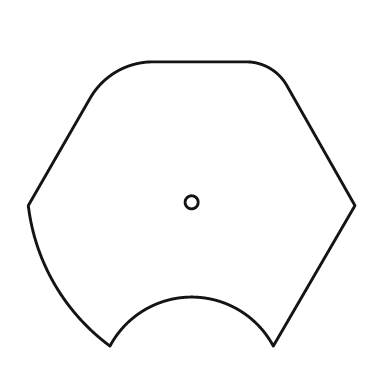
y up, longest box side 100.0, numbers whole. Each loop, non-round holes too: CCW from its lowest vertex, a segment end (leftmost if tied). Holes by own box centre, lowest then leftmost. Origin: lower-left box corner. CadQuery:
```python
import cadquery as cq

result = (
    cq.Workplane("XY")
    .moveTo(25.0, 0.0)
    .threePointArc((50.0, 15.0), (75.0, 0.0))
    .lineTo(100.0, 43.0)
    .lineTo(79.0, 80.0)
    .threePointArc((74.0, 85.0), (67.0, 87.0))
    .lineTo(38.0, 87.0)
    .threePointArc((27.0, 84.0), (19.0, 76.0))
    .lineTo(0.0, 43.0)
    .threePointArc((8.0, 19.0), (25.0, 0.0))
    .close()
    .moveTo(50.0, 44.0)
    .circle(2.0)
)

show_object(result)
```